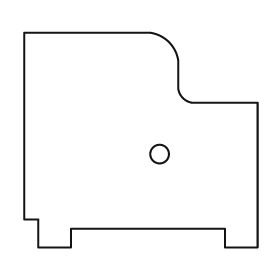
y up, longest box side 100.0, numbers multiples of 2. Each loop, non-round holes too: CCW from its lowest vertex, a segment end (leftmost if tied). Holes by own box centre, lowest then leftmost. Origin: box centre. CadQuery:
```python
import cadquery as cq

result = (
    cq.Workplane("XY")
    .moveTo(-44.0, -46.0)
    .lineTo(-30.0, -46.0)
    .lineTo(-30.0, -38.0)
    .lineTo(36.0, -38.0)
    .lineTo(36.0, -46.0)
    .lineTo(50.0, -46.0)
    .lineTo(50.0, 16.0)
    .lineTo(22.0, 16.0)
    .threePointArc((18.0, 18.0), (16.0, 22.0))
    .lineTo(16.0, 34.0)
    .threePointArc((12.0, 42.0), (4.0, 46.0))
    .lineTo(-50.0, 46.0)
    .lineTo(-50.0, -34.0)
    .lineTo(-44.0, -34.0)
    .close()
    .moveTo(8.0, -6.0)
    .circle(4.0)
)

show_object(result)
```